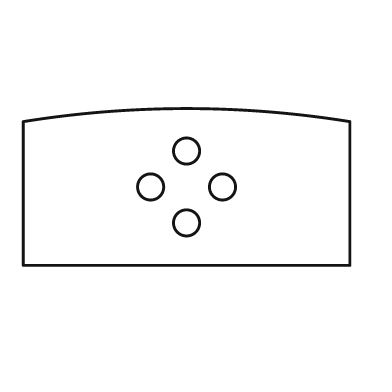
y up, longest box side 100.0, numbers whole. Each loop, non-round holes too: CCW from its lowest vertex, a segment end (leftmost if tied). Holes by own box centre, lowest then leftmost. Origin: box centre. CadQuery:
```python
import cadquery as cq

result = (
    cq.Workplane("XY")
    .moveTo(-50.0, -24.0)
    .lineTo(50.0, -24.0)
    .lineTo(50.0, 20.0)
    .threePointArc((0.0, 24.0), (-50.0, 20.0))
    .close()
    .moveTo(0.0, -11.0)
    .circle(4.0)
    .moveTo(-11.0, 0.0)
    .circle(4.0)
    .moveTo(11.0, 0.0)
    .circle(4.0)
    .moveTo(0.0, 11.0)
    .circle(4.0)
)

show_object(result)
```